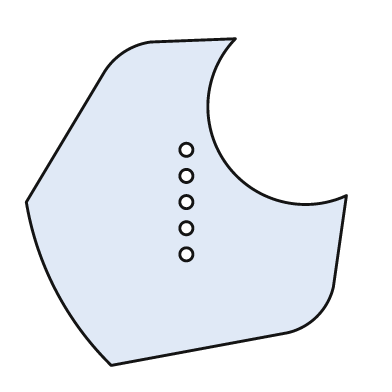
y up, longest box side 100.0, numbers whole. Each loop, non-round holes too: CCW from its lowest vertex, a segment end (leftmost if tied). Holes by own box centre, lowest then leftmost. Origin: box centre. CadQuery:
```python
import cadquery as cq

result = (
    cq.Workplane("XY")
    .moveTo(-23.0, -50.0)
    .lineTo(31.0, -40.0)
    .threePointArc((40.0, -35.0), (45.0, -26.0))
    .lineTo(49.0, 2.0)
    .threePointArc((12.0, 12.0), (15.0, 50.0))
    .lineTo(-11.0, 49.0)
    .threePointArc((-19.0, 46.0), (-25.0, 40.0))
    .lineTo(-49.0, 0.0)
    .threePointArc((-40.0, -27.0), (-23.0, -50.0))
    .close()
    .moveTo(0.0, -16.0)
    .circle(2.0)
    .moveTo(0.0, -8.0)
    .circle(2.0)
    .moveTo(0.0, 0.0)
    .circle(2.0)
    .moveTo(0.0, 8.0)
    .circle(2.0)
    .moveTo(0.0, 16.0)
    .circle(2.0)
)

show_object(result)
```